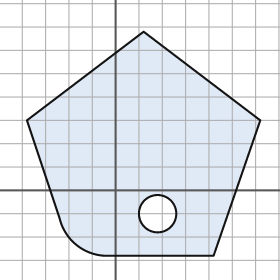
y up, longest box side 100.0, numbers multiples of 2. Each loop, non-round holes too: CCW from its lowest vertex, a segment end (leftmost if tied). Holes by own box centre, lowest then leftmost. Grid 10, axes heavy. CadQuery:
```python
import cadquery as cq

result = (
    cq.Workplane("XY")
    .moveTo(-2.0, -28.0)
    .lineTo(42.0, -28.0)
    .lineTo(62.0, 30.0)
    .lineTo(12.0, 68.0)
    .lineTo(-38.0, 30.0)
    .lineTo(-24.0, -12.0)
    .threePointArc((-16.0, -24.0), (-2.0, -28.0))
    .close()
    .moveTo(18.0, -10.0)
    .circle(8.0)
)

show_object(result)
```